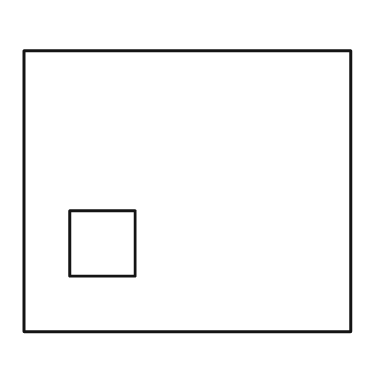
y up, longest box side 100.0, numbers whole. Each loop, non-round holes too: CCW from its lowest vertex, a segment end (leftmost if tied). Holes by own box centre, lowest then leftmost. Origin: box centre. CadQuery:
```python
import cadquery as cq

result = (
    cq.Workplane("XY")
    .moveTo(-50.0, -43.0)
    .lineTo(50.0, -43.0)
    .lineTo(50.0, 43.0)
    .lineTo(-50.0, 43.0)
    .close()
    .moveTo(-36.0, -26.0)
    .lineTo(-16.0, -26.0)
    .lineTo(-16.0, -6.0)
    .lineTo(-36.0, -6.0)
    .close()
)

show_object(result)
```